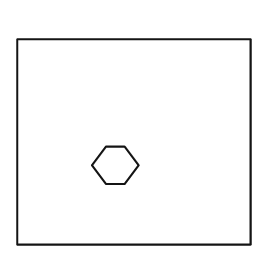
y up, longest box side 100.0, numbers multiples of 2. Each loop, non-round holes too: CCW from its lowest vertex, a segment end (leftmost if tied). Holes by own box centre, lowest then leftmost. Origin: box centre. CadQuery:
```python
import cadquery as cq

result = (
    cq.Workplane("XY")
    .moveTo(-50.0, -44.0)
    .lineTo(50.0, -44.0)
    .lineTo(50.0, 44.0)
    .lineTo(-50.0, 44.0)
    .close()
    .moveTo(-12.0, -18.0)
    .lineTo(-4.0, -18.0)
    .lineTo(2.0, -10.0)
    .lineTo(-4.0, -2.0)
    .lineTo(-12.0, -2.0)
    .lineTo(-18.0, -10.0)
    .close()
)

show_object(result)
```